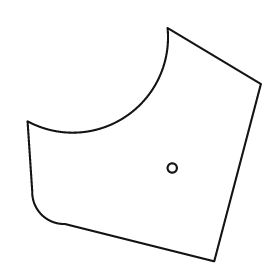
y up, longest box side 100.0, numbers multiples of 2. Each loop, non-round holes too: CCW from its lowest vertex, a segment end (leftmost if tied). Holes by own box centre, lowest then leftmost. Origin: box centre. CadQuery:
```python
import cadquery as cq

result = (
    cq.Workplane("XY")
    .moveTo(30.0, -50.0)
    .lineTo(50.0, 26.0)
    .lineTo(10.0, 50.0)
    .threePointArc((-8.0, 12.0), (-50.0, 10.0))
    .lineTo(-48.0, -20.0)
    .threePointArc((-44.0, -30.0), (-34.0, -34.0))
    .close()
    .moveTo(12.0, -10.0)
    .circle(2.0)
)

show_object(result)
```